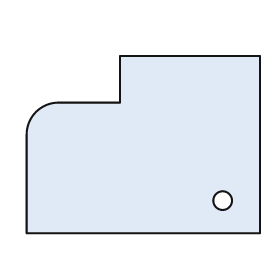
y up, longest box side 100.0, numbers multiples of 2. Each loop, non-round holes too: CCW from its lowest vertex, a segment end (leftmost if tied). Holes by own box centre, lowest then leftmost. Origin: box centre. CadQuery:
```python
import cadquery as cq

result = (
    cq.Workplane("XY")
    .moveTo(-50.0, -38.0)
    .lineTo(50.0, -38.0)
    .lineTo(50.0, 38.0)
    .lineTo(-10.0, 38.0)
    .lineTo(-10.0, 18.0)
    .lineTo(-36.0, 18.0)
    .threePointArc((-46.0, 14.0), (-50.0, 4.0))
    .close()
    .moveTo(34.0, -24.0)
    .circle(4.0)
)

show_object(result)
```